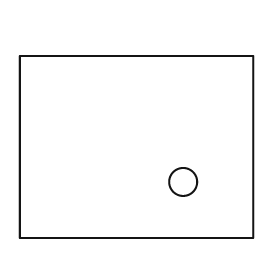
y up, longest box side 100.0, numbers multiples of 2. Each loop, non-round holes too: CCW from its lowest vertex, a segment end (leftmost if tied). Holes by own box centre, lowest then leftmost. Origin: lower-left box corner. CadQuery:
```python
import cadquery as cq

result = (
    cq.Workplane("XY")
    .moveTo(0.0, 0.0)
    .lineTo(100.0, 0.0)
    .lineTo(100.0, 78.0)
    .lineTo(0.0, 78.0)
    .close()
    .moveTo(70.0, 24.0)
    .circle(6.0)
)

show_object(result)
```